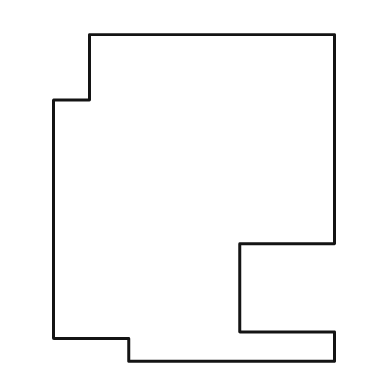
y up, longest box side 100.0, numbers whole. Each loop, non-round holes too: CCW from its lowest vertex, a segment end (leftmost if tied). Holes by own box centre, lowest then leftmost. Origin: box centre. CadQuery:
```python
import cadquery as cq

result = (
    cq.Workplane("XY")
    .moveTo(-20.0, -50.0)
    .lineTo(43.0, -50.0)
    .lineTo(43.0, -41.0)
    .lineTo(14.0, -41.0)
    .lineTo(14.0, -14.0)
    .lineTo(43.0, -14.0)
    .lineTo(43.0, 50.0)
    .lineTo(-32.0, 50.0)
    .lineTo(-32.0, 30.0)
    .lineTo(-43.0, 30.0)
    .lineTo(-43.0, -43.0)
    .lineTo(-20.0, -43.0)
    .close()
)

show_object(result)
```